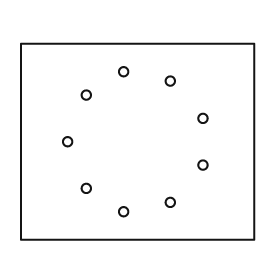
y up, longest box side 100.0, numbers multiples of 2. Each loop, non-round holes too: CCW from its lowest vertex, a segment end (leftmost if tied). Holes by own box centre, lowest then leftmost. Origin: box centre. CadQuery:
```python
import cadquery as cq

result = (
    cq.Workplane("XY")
    .moveTo(-50.0, -42.0)
    .lineTo(50.0, -42.0)
    .lineTo(50.0, 42.0)
    .lineTo(-50.0, 42.0)
    .close()
    .moveTo(-6.0, -30.0)
    .circle(2.0)
    .moveTo(14.0, -26.0)
    .circle(2.0)
    .moveTo(-22.0, -20.0)
    .circle(2.0)
    .moveTo(28.0, -10.0)
    .circle(2.0)
    .moveTo(-30.0, 0.0)
    .circle(2.0)
    .moveTo(28.0, 10.0)
    .circle(2.0)
    .moveTo(-22.0, 20.0)
    .circle(2.0)
    .moveTo(14.0, 26.0)
    .circle(2.0)
    .moveTo(-6.0, 30.0)
    .circle(2.0)
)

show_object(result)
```